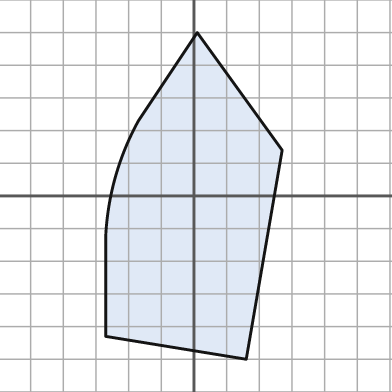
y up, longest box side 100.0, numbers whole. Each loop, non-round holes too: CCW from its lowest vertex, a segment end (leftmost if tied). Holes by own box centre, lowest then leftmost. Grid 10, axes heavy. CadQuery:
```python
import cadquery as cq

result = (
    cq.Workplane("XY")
    .moveTo(16.0, -50.0)
    .lineTo(27.0, 14.0)
    .lineTo(1.0, 50.0)
    .lineTo(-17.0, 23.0)
    .threePointArc((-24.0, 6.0), (-27.0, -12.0))
    .lineTo(-27.0, -43.0)
    .close()
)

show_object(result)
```